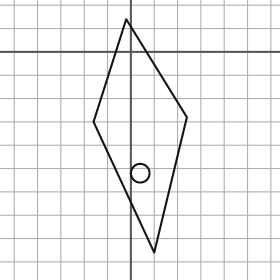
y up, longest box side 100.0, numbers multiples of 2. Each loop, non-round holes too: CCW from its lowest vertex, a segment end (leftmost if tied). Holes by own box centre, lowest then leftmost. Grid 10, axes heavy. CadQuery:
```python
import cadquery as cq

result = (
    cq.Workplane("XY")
    .moveTo(10.0, -86.0)
    .lineTo(24.0, -28.0)
    .lineTo(-2.0, 14.0)
    .lineTo(-16.0, -30.0)
    .close()
    .moveTo(4.0, -52.0)
    .circle(4.0)
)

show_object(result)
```